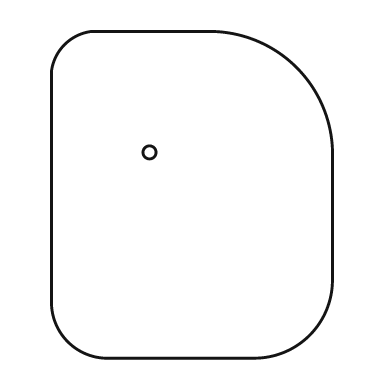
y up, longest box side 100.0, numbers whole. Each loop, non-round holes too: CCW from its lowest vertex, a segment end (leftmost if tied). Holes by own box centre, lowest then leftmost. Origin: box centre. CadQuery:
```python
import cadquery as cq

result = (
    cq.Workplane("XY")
    .moveTo(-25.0, -50.0)
    .lineTo(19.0, -50.0)
    .threePointArc((36.0, -43.0), (43.0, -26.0))
    .lineTo(43.0, 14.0)
    .threePointArc((32.0, 39.0), (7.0, 50.0))
    .lineTo(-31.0, 50.0)
    .threePointArc((-39.0, 46.0), (-43.0, 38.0))
    .lineTo(-43.0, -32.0)
    .threePointArc((-38.0, -45.0), (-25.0, -50.0))
    .close()
    .moveTo(-13.0, 13.0)
    .circle(2.0)
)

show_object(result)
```